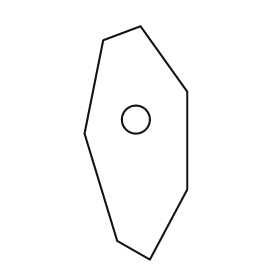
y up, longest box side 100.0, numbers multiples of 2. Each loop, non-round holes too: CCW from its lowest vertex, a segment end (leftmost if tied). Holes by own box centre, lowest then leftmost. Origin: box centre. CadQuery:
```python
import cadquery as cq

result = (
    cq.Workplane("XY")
    .moveTo(6.0, -50.0)
    .lineTo(22.0, -20.0)
    .lineTo(22.0, 22.0)
    .lineTo(2.0, 50.0)
    .lineTo(-14.0, 44.0)
    .lineTo(-22.0, 4.0)
    .lineTo(-8.0, -42.0)
    .close()
    .moveTo(0.0, 10.0)
    .circle(6.0)
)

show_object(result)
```